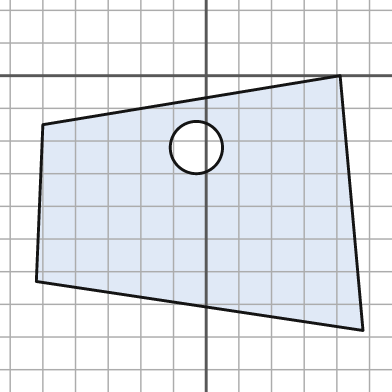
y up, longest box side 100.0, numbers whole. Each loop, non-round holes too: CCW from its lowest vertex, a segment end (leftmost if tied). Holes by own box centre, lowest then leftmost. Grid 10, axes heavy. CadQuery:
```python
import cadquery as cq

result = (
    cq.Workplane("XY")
    .moveTo(48.0, -78.0)
    .lineTo(41.0, 0.0)
    .lineTo(-50.0, -15.0)
    .lineTo(-52.0, -63.0)
    .close()
    .moveTo(-3.0, -22.0)
    .circle(8.0)
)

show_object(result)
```